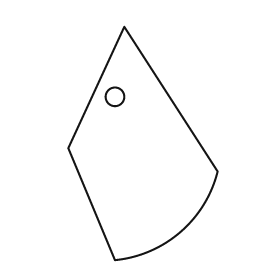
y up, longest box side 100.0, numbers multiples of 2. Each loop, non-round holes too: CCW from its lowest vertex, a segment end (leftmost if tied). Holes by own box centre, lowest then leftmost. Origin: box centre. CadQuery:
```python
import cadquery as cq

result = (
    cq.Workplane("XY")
    .moveTo(-12.0, -50.0)
    .threePointArc((16.0, -38.0), (32.0, -12.0))
    .lineTo(-8.0, 50.0)
    .lineTo(-32.0, -2.0)
    .close()
    .moveTo(-12.0, 20.0)
    .circle(4.0)
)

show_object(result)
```